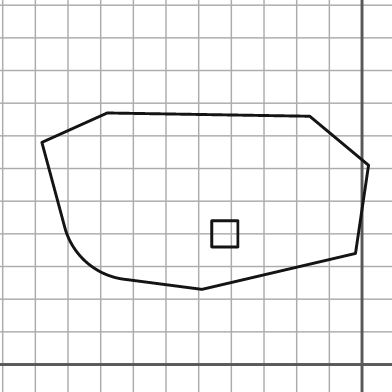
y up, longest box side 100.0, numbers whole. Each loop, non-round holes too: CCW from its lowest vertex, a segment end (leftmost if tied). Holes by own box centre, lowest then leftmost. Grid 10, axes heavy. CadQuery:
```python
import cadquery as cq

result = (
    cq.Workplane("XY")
    .moveTo(-49.0, 23.0)
    .lineTo(-2.0, 34.0)
    .lineTo(2.0, 61.0)
    .lineTo(-16.0, 76.0)
    .lineTo(-78.0, 77.0)
    .lineTo(-98.0, 68.0)
    .lineTo(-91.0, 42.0)
    .threePointArc((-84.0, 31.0), (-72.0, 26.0))
    .close()
    .moveTo(-46.0, 36.0)
    .lineTo(-38.0, 36.0)
    .lineTo(-38.0, 44.0)
    .lineTo(-46.0, 44.0)
    .close()
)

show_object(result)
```